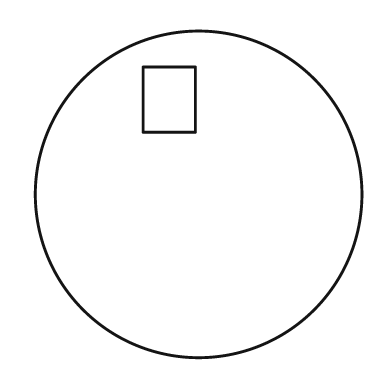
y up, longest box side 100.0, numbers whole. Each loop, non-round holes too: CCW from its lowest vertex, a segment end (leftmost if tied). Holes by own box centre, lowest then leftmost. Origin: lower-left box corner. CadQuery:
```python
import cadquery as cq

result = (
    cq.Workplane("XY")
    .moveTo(50.0, 50.0)
    .circle(50.0)
    .moveTo(33.0, 69.0)
    .lineTo(49.0, 69.0)
    .lineTo(49.0, 89.0)
    .lineTo(33.0, 89.0)
    .close()
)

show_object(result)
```